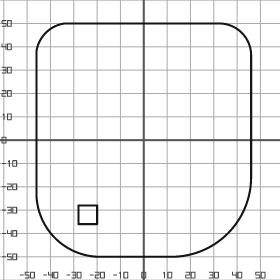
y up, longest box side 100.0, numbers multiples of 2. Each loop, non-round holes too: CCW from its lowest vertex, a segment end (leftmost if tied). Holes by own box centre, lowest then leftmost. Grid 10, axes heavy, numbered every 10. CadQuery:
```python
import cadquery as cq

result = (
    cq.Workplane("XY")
    .moveTo(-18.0, -50.0)
    .lineTo(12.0, -50.0)
    .threePointArc((36.0, -40.0), (46.0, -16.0))
    .lineTo(46.0, 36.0)
    .threePointArc((42.0, 46.0), (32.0, 50.0))
    .lineTo(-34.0, 50.0)
    .threePointArc((-42.0, 46.0), (-46.0, 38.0))
    .lineTo(-46.0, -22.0)
    .threePointArc((-38.0, -42.0), (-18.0, -50.0))
    .close()
    .moveTo(-28.0, -36.0)
    .lineTo(-20.0, -36.0)
    .lineTo(-20.0, -28.0)
    .lineTo(-28.0, -28.0)
    .close()
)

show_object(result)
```